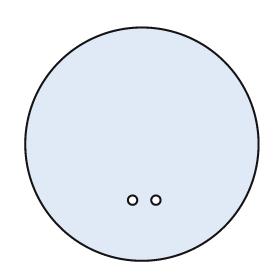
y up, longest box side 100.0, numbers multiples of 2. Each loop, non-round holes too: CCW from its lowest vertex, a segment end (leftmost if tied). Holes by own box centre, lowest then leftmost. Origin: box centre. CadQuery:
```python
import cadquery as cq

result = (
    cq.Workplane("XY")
    .moveTo(0.0, 0.0)
    .circle(50.0)
    .moveTo(-4.0, -24.0)
    .circle(2.0)
    .moveTo(6.0, -24.0)
    .circle(2.0)
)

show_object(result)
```